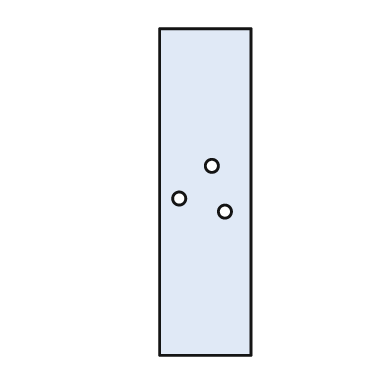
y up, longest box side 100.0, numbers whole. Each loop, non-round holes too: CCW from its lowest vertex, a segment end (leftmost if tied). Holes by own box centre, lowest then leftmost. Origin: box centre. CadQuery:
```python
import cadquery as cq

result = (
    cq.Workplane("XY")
    .moveTo(-14.0, -50.0)
    .lineTo(14.0, -50.0)
    .lineTo(14.0, 50.0)
    .lineTo(-14.0, 50.0)
    .close()
    .moveTo(6.0, -6.0)
    .circle(2.0)
    .moveTo(-8.0, -2.0)
    .circle(2.0)
    .moveTo(2.0, 8.0)
    .circle(2.0)
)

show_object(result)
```